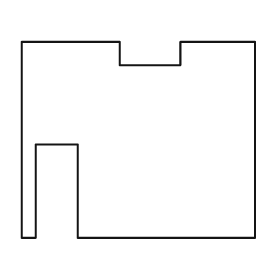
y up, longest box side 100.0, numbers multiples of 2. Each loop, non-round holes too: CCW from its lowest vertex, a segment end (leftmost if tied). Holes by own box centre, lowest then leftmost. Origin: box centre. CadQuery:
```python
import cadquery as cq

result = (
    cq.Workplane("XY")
    .moveTo(-50.0, -42.0)
    .lineTo(-44.0, -42.0)
    .lineTo(-44.0, -2.0)
    .lineTo(-26.0, -2.0)
    .lineTo(-26.0, -42.0)
    .lineTo(50.0, -42.0)
    .lineTo(50.0, 42.0)
    .lineTo(18.0, 42.0)
    .lineTo(18.0, 32.0)
    .lineTo(-8.0, 32.0)
    .lineTo(-8.0, 42.0)
    .lineTo(-50.0, 42.0)
    .close()
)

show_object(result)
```